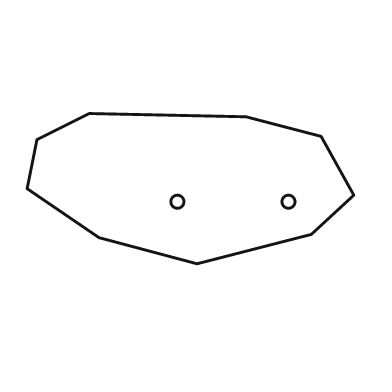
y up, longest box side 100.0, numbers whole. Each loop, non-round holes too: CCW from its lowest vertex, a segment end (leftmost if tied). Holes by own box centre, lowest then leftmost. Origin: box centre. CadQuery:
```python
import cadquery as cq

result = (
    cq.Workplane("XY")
    .moveTo(2.0, -23.0)
    .lineTo(37.0, -14.0)
    .lineTo(50.0, -2.0)
    .lineTo(40.0, 16.0)
    .lineTo(17.0, 22.0)
    .lineTo(-31.0, 23.0)
    .lineTo(-47.0, 15.0)
    .lineTo(-50.0, 0.0)
    .lineTo(-28.0, -15.0)
    .close()
    .moveTo(-4.0, -4.0)
    .circle(2.0)
    .moveTo(30.0, -4.0)
    .circle(2.0)
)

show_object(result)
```